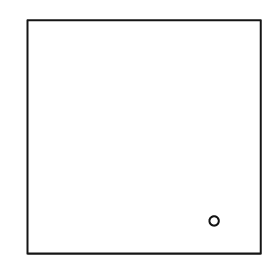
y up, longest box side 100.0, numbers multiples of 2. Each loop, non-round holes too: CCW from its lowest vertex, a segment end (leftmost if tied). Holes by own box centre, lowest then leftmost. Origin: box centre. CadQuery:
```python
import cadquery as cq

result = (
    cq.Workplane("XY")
    .moveTo(-50.0, -50.0)
    .lineTo(50.0, -50.0)
    .lineTo(50.0, 50.0)
    .lineTo(-50.0, 50.0)
    .close()
    .moveTo(30.0, -36.0)
    .circle(2.0)
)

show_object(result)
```